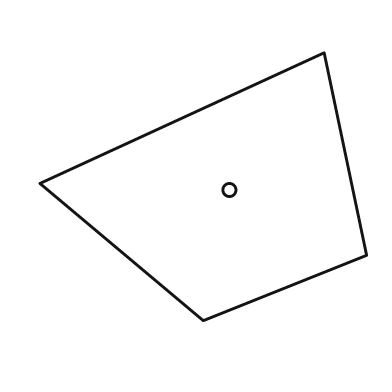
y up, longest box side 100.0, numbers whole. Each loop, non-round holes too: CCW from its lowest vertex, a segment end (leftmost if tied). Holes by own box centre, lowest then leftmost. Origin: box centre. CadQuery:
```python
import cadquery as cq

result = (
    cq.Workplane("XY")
    .moveTo(0.0, -41.0)
    .lineTo(50.0, -21.0)
    .lineTo(37.0, 41.0)
    .lineTo(-50.0, 1.0)
    .close()
    .moveTo(8.0, -1.0)
    .circle(2.0)
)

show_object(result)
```